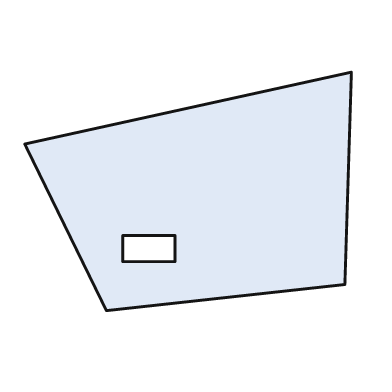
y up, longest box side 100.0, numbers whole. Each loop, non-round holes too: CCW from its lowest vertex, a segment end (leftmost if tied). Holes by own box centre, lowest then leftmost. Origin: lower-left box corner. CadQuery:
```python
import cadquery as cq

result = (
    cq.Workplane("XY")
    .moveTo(25.0, 0.0)
    .lineTo(98.0, 8.0)
    .lineTo(100.0, 73.0)
    .lineTo(0.0, 51.0)
    .close()
    .moveTo(30.0, 15.0)
    .lineTo(46.0, 15.0)
    .lineTo(46.0, 23.0)
    .lineTo(30.0, 23.0)
    .close()
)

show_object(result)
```